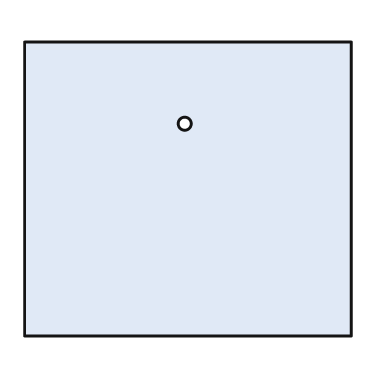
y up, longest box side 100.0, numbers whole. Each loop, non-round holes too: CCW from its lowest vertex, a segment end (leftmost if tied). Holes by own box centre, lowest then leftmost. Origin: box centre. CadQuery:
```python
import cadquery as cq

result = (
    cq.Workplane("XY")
    .moveTo(-50.0, -45.0)
    .lineTo(50.0, -45.0)
    .lineTo(50.0, 45.0)
    .lineTo(-50.0, 45.0)
    .close()
    .moveTo(-1.0, 20.0)
    .circle(2.0)
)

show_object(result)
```